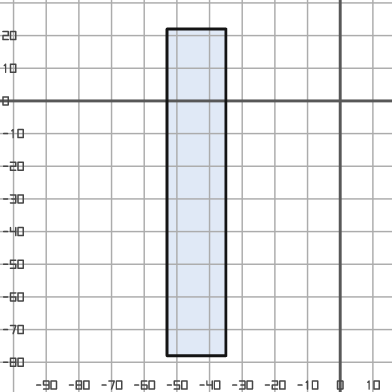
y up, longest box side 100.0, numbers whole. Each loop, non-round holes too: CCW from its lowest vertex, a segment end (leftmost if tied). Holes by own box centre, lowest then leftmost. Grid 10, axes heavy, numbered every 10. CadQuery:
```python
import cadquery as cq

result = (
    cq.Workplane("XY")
    .moveTo(-53.0, -78.0)
    .lineTo(-35.0, -78.0)
    .lineTo(-35.0, 22.0)
    .lineTo(-53.0, 22.0)
    .close()
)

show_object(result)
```